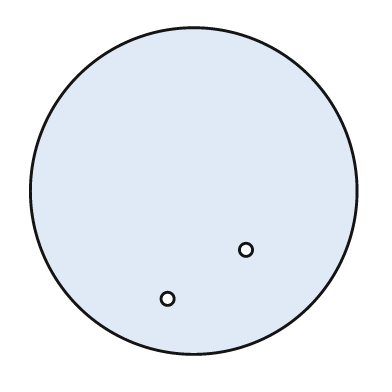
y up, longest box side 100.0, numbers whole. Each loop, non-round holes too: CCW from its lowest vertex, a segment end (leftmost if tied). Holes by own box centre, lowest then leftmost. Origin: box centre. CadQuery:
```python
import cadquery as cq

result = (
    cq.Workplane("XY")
    .moveTo(0.0, 0.0)
    .circle(50.0)
    .moveTo(-8.0, -33.0)
    .circle(2.0)
    .moveTo(16.0, -18.0)
    .circle(2.0)
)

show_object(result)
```